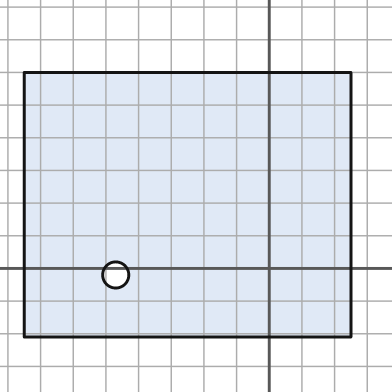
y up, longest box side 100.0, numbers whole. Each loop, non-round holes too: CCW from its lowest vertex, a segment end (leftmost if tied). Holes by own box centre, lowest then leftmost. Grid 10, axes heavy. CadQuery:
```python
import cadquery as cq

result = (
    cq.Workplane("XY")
    .moveTo(-75.0, -21.0)
    .lineTo(25.0, -21.0)
    .lineTo(25.0, 60.0)
    .lineTo(-75.0, 60.0)
    .close()
    .moveTo(-47.0, -2.0)
    .circle(4.0)
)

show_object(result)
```